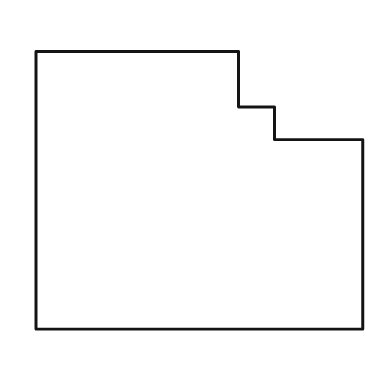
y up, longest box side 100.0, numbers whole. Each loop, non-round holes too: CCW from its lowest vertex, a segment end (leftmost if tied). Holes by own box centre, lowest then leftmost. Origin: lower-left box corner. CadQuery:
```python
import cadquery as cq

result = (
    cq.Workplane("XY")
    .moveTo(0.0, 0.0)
    .lineTo(100.0, 0.0)
    .lineTo(100.0, 58.0)
    .lineTo(73.0, 58.0)
    .lineTo(73.0, 68.0)
    .lineTo(62.0, 68.0)
    .lineTo(62.0, 85.0)
    .lineTo(0.0, 85.0)
    .close()
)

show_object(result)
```